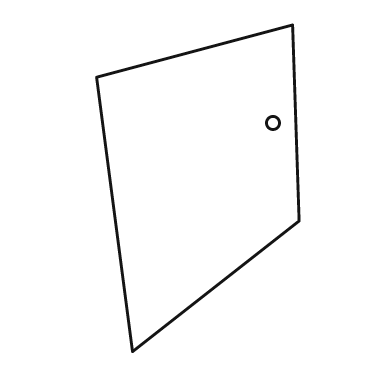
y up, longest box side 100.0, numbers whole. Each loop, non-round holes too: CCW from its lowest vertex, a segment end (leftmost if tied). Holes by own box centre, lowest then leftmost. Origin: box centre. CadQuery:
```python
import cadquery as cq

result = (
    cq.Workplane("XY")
    .moveTo(-20.0, -50.0)
    .lineTo(31.0, -10.0)
    .lineTo(29.0, 50.0)
    .lineTo(-31.0, 34.0)
    .close()
    .moveTo(23.0, 20.0)
    .circle(2.0)
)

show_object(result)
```